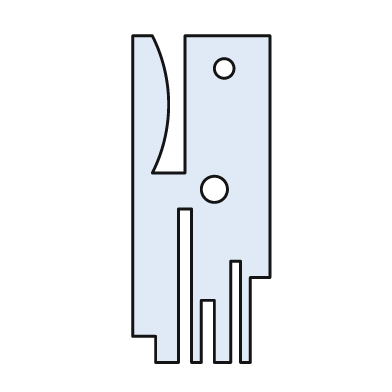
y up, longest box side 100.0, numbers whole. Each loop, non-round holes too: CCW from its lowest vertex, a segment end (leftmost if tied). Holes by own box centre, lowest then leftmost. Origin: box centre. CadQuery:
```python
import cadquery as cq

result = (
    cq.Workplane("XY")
    .moveTo(-14.0, -50.0)
    .lineTo(-7.0, -50.0)
    .lineTo(-7.0, -3.0)
    .lineTo(-3.0, -3.0)
    .lineTo(-3.0, -50.0)
    .lineTo(0.0, -50.0)
    .lineTo(0.0, -31.0)
    .lineTo(4.0, -31.0)
    .lineTo(4.0, -50.0)
    .lineTo(9.0, -50.0)
    .lineTo(9.0, -19.0)
    .lineTo(12.0, -19.0)
    .lineTo(12.0, -50.0)
    .lineTo(15.0, -50.0)
    .lineTo(15.0, -24.0)
    .lineTo(21.0, -24.0)
    .lineTo(21.0, 50.0)
    .lineTo(-5.0, 50.0)
    .lineTo(-5.0, 8.0)
    .lineTo(-15.0, 8.0)
    .threePointArc((-10.0, 29.0), (-15.0, 50.0))
    .lineTo(-21.0, 50.0)
    .lineTo(-21.0, -42.0)
    .lineTo(-14.0, -42.0)
    .close()
    .moveTo(4.0, 3.0)
    .circle(4.0)
    .moveTo(7.0, 40.0)
    .circle(3.0)
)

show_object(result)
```